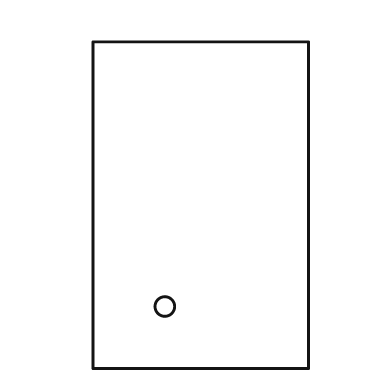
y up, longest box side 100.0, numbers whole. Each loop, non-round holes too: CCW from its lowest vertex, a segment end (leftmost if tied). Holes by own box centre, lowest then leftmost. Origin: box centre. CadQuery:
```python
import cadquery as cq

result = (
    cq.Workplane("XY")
    .moveTo(-33.0, -50.0)
    .lineTo(33.0, -50.0)
    .lineTo(33.0, 50.0)
    .lineTo(-33.0, 50.0)
    .close()
    .moveTo(-11.0, -31.0)
    .circle(3.0)
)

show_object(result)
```